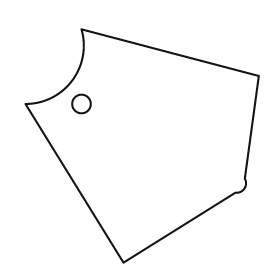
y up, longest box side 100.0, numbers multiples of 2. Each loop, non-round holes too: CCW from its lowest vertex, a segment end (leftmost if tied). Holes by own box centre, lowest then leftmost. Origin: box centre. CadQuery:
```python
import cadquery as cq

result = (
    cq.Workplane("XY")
    .moveTo(-8.0, -50.0)
    .lineTo(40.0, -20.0)
    .threePointArc((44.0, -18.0), (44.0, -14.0))
    .lineTo(50.0, 30.0)
    .lineTo(-26.0, 50.0)
    .threePointArc((-30.0, 28.0), (-50.0, 18.0))
    .close()
    .moveTo(-26.0, 18.0)
    .circle(4.0)
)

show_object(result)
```